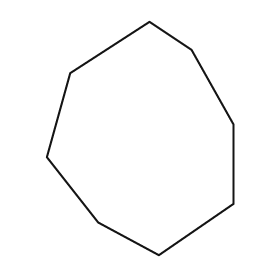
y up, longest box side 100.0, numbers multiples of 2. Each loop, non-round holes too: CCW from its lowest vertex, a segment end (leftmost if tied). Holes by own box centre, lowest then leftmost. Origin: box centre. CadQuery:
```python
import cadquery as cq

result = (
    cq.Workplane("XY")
    .moveTo(8.0, -50.0)
    .lineTo(40.0, -28.0)
    .lineTo(40.0, 6.0)
    .lineTo(22.0, 38.0)
    .lineTo(4.0, 50.0)
    .lineTo(-30.0, 28.0)
    .lineTo(-40.0, -8.0)
    .lineTo(-18.0, -36.0)
    .close()
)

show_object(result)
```